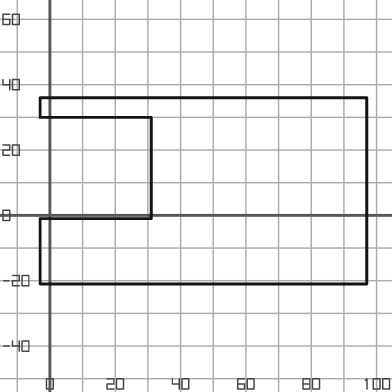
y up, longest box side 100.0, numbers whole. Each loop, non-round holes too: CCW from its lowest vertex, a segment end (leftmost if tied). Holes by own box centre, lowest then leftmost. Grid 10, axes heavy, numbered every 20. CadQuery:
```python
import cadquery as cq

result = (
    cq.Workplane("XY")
    .moveTo(-3.0, -21.0)
    .lineTo(97.0, -21.0)
    .lineTo(97.0, 36.0)
    .lineTo(-3.0, 36.0)
    .lineTo(-3.0, 30.0)
    .lineTo(31.0, 30.0)
    .lineTo(31.0, -1.0)
    .lineTo(-3.0, -1.0)
    .close()
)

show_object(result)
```